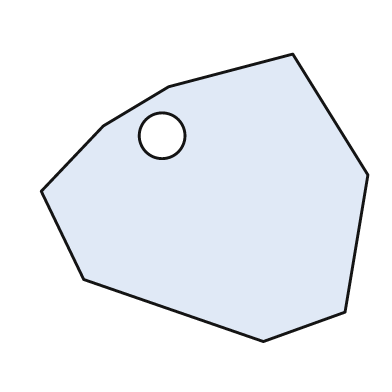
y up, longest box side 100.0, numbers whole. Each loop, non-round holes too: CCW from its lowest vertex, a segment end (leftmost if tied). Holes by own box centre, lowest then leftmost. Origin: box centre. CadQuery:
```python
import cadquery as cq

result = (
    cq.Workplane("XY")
    .moveTo(18.0, -44.0)
    .lineTo(43.0, -35.0)
    .lineTo(50.0, 7.0)
    .lineTo(27.0, 44.0)
    .lineTo(-11.0, 34.0)
    .lineTo(-31.0, 22.0)
    .lineTo(-50.0, 2.0)
    .lineTo(-37.0, -25.0)
    .close()
    .moveTo(-13.0, 19.0)
    .circle(7.0)
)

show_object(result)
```